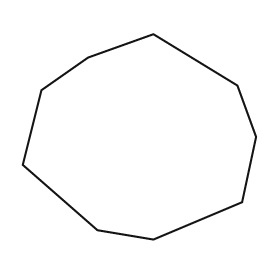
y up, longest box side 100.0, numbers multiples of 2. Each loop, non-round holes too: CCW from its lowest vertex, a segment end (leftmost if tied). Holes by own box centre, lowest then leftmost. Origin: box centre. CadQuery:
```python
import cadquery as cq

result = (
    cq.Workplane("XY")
    .moveTo(6.0, -44.0)
    .lineTo(44.0, -28.0)
    .lineTo(50.0, 0.0)
    .lineTo(42.0, 22.0)
    .lineTo(6.0, 44.0)
    .lineTo(-22.0, 34.0)
    .lineTo(-42.0, 20.0)
    .lineTo(-50.0, -12.0)
    .lineTo(-18.0, -40.0)
    .close()
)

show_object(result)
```